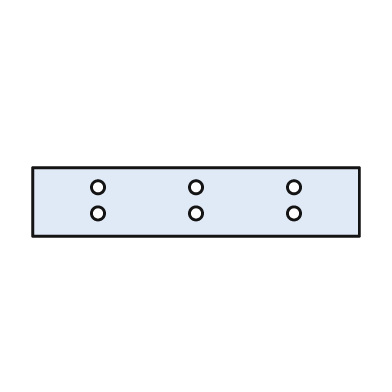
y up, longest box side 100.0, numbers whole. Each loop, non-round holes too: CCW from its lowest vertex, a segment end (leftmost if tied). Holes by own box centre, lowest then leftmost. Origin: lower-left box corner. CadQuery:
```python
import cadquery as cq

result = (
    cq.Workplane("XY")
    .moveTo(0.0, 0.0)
    .lineTo(100.0, 0.0)
    .lineTo(100.0, 21.0)
    .lineTo(0.0, 21.0)
    .close()
    .moveTo(20.0, 7.0)
    .circle(2.0)
    .moveTo(50.0, 7.0)
    .circle(2.0)
    .moveTo(80.0, 7.0)
    .circle(2.0)
    .moveTo(20.0, 15.0)
    .circle(2.0)
    .moveTo(50.0, 15.0)
    .circle(2.0)
    .moveTo(80.0, 15.0)
    .circle(2.0)
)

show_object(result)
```